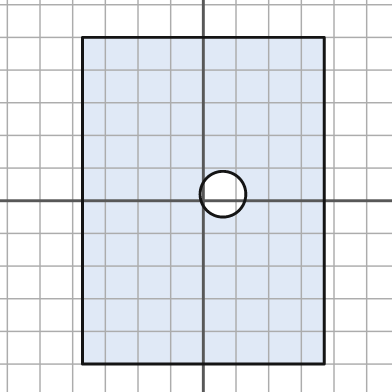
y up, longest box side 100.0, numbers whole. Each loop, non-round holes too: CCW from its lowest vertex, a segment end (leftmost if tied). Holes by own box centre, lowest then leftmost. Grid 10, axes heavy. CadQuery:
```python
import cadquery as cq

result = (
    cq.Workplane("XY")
    .moveTo(-37.0, -50.0)
    .lineTo(37.0, -50.0)
    .lineTo(37.0, 50.0)
    .lineTo(-37.0, 50.0)
    .close()
    .moveTo(6.0, 2.0)
    .circle(7.0)
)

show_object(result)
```